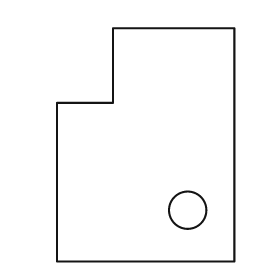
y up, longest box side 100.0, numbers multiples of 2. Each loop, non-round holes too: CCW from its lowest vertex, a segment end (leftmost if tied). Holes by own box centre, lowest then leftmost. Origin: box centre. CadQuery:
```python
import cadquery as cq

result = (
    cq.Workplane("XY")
    .moveTo(-38.0, -50.0)
    .lineTo(38.0, -50.0)
    .lineTo(38.0, 50.0)
    .lineTo(-14.0, 50.0)
    .lineTo(-14.0, 18.0)
    .lineTo(-38.0, 18.0)
    .close()
    .moveTo(18.0, -28.0)
    .circle(8.0)
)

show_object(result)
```